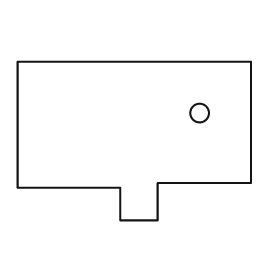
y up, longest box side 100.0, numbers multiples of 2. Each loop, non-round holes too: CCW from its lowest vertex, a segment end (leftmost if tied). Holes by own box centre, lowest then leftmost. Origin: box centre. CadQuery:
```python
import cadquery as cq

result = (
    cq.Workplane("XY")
    .moveTo(-6.0, -34.0)
    .lineTo(10.0, -34.0)
    .lineTo(10.0, -18.0)
    .lineTo(50.0, -18.0)
    .lineTo(50.0, 34.0)
    .lineTo(-50.0, 34.0)
    .lineTo(-50.0, -20.0)
    .lineTo(-6.0, -20.0)
    .close()
    .moveTo(28.0, 12.0)
    .circle(4.0)
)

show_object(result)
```